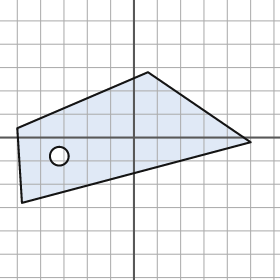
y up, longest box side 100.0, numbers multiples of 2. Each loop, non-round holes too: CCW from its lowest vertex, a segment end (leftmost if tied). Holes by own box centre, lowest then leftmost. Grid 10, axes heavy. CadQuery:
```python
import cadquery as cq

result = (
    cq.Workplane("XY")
    .moveTo(-48.0, -28.0)
    .lineTo(50.0, -2.0)
    .lineTo(6.0, 28.0)
    .lineTo(-50.0, 4.0)
    .close()
    .moveTo(-32.0, -8.0)
    .circle(4.0)
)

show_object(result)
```